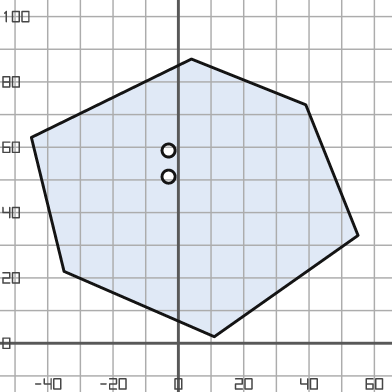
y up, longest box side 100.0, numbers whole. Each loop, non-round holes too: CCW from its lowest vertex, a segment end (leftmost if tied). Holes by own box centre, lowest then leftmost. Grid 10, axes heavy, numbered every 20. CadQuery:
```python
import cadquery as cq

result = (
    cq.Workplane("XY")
    .moveTo(11.0, 2.0)
    .lineTo(55.0, 33.0)
    .lineTo(39.0, 73.0)
    .lineTo(4.0, 87.0)
    .lineTo(-45.0, 63.0)
    .lineTo(-35.0, 22.0)
    .close()
    .moveTo(-3.0, 51.0)
    .circle(2.0)
    .moveTo(-3.0, 59.0)
    .circle(2.0)
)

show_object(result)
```